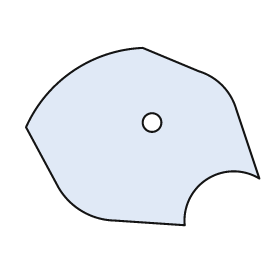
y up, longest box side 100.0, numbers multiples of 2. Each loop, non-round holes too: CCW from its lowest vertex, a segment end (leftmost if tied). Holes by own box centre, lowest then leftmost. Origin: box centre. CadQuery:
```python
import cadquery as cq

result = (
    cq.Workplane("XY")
    .moveTo(18.0, -38.0)
    .threePointArc((28.0, -18.0), (50.0, -18.0))
    .lineTo(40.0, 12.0)
    .threePointArc((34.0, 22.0), (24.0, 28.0))
    .lineTo(0.0, 38.0)
    .threePointArc((-30.0, 28.0), (-50.0, 4.0))
    .lineTo(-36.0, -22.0)
    .threePointArc((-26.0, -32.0), (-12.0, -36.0))
    .close()
    .moveTo(4.0, 6.0)
    .circle(4.0)
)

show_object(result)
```